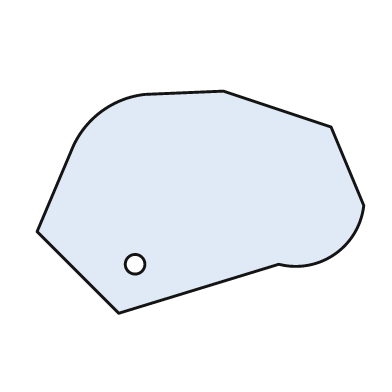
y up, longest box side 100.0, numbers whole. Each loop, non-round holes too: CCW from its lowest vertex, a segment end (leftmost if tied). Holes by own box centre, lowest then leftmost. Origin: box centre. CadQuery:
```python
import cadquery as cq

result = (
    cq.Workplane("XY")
    .moveTo(-25.0, -34.0)
    .lineTo(24.0, -19.0)
    .threePointArc((41.0, -16.0), (50.0, -1.0))
    .lineTo(40.0, 23.0)
    .lineTo(7.0, 34.0)
    .lineTo(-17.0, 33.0)
    .threePointArc((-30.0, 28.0), (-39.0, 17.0))
    .lineTo(-50.0, -9.0)
    .close()
    .moveTo(-20.0, -19.0)
    .circle(3.0)
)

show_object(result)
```